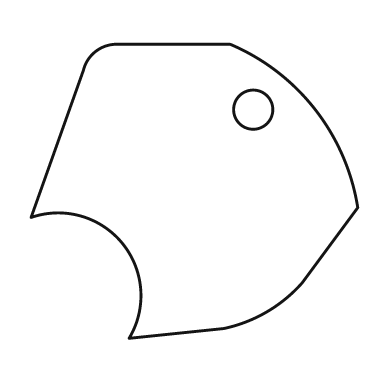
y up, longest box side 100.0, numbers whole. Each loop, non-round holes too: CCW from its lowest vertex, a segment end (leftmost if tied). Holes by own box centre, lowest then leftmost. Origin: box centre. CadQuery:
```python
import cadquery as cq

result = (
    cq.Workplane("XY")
    .moveTo(-20.0, -45.0)
    .lineTo(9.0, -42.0)
    .threePointArc((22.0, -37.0), (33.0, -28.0))
    .lineTo(50.0, -5.0)
    .threePointArc((37.0, 25.0), (11.0, 45.0))
    .lineTo(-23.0, 45.0)
    .threePointArc((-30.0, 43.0), (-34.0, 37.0))
    .lineTo(-50.0, -8.0)
    .threePointArc((-22.0, -16.0), (-20.0, -45.0))
    .close()
    .moveTo(18.0, 25.0)
    .circle(6.0)
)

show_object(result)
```